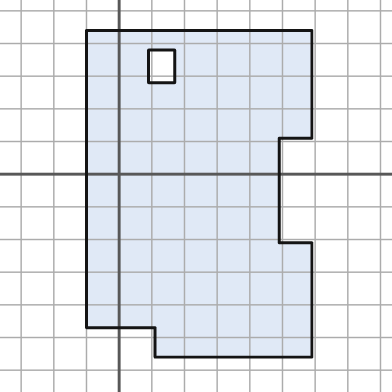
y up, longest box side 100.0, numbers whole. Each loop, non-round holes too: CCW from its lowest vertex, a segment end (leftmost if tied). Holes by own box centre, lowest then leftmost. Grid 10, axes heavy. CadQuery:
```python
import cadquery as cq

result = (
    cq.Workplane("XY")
    .moveTo(11.0, -56.0)
    .lineTo(59.0, -56.0)
    .lineTo(59.0, -21.0)
    .lineTo(49.0, -21.0)
    .lineTo(49.0, 11.0)
    .lineTo(59.0, 11.0)
    .lineTo(59.0, 44.0)
    .lineTo(-10.0, 44.0)
    .lineTo(-10.0, -47.0)
    .lineTo(11.0, -47.0)
    .close()
    .moveTo(9.0, 28.0)
    .lineTo(17.0, 28.0)
    .lineTo(17.0, 38.0)
    .lineTo(9.0, 38.0)
    .close()
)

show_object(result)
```